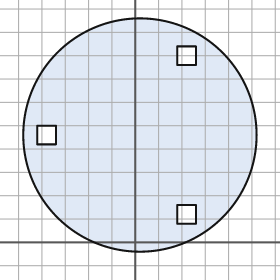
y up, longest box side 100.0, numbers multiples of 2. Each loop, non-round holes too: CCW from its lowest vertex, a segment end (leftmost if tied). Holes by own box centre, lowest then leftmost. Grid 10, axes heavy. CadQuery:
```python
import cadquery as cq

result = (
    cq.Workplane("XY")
    .moveTo(2.0, 46.0)
    .circle(50.0)
    .moveTo(18.0, 8.0)
    .lineTo(26.0, 8.0)
    .lineTo(26.0, 16.0)
    .lineTo(18.0, 16.0)
    .close()
    .moveTo(-42.0, 42.0)
    .lineTo(-34.0, 42.0)
    .lineTo(-34.0, 50.0)
    .lineTo(-42.0, 50.0)
    .close()
    .moveTo(18.0, 76.0)
    .lineTo(26.0, 76.0)
    .lineTo(26.0, 84.0)
    .lineTo(18.0, 84.0)
    .close()
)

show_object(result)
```